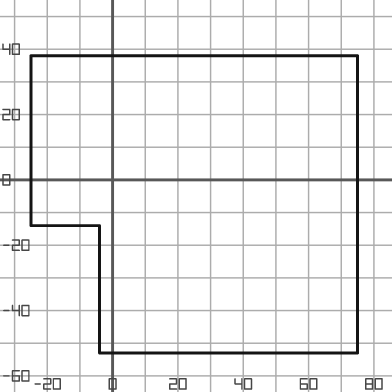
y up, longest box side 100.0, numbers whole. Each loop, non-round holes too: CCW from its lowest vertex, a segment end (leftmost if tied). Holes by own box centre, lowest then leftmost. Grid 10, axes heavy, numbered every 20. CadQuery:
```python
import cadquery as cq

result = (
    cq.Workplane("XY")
    .moveTo(-4.0, -53.0)
    .lineTo(75.0, -53.0)
    .lineTo(75.0, 38.0)
    .lineTo(-25.0, 38.0)
    .lineTo(-25.0, -14.0)
    .lineTo(-4.0, -14.0)
    .close()
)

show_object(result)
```